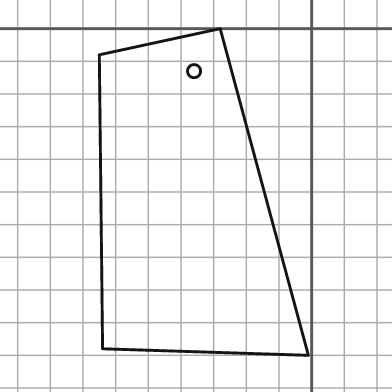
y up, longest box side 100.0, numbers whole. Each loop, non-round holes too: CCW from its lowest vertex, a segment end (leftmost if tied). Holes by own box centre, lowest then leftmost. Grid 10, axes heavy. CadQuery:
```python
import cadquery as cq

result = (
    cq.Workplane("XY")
    .moveTo(-1.0, -100.0)
    .lineTo(-28.0, 0.0)
    .lineTo(-65.0, -8.0)
    .lineTo(-64.0, -98.0)
    .close()
    .moveTo(-36.0, -13.0)
    .circle(2.0)
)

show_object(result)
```